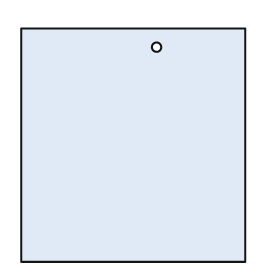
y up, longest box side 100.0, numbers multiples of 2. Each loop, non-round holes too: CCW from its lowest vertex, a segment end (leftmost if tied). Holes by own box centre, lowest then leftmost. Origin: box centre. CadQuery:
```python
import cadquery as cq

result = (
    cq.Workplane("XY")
    .moveTo(-48.0, -50.0)
    .lineTo(48.0, -50.0)
    .lineTo(48.0, 50.0)
    .lineTo(-48.0, 50.0)
    .close()
    .moveTo(10.0, 42.0)
    .circle(2.0)
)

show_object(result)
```